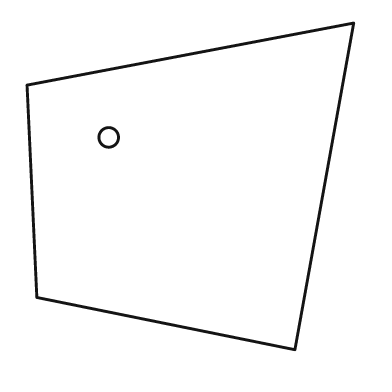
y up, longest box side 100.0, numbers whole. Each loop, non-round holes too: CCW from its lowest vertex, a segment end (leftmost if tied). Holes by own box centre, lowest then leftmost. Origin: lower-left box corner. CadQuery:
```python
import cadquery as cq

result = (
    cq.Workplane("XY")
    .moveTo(82.0, 0.0)
    .lineTo(100.0, 100.0)
    .lineTo(0.0, 81.0)
    .lineTo(3.0, 16.0)
    .close()
    .moveTo(25.0, 65.0)
    .circle(3.0)
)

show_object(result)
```